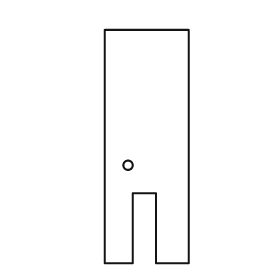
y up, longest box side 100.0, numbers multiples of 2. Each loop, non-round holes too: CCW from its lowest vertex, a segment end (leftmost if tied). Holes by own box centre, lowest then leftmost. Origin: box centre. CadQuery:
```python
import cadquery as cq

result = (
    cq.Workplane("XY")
    .moveTo(-18.0, -50.0)
    .lineTo(-6.0, -50.0)
    .lineTo(-6.0, -20.0)
    .lineTo(4.0, -20.0)
    .lineTo(4.0, -50.0)
    .lineTo(18.0, -50.0)
    .lineTo(18.0, 50.0)
    .lineTo(-18.0, 50.0)
    .close()
    .moveTo(-8.0, -8.0)
    .circle(2.0)
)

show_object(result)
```